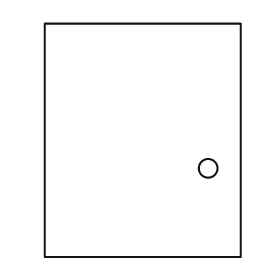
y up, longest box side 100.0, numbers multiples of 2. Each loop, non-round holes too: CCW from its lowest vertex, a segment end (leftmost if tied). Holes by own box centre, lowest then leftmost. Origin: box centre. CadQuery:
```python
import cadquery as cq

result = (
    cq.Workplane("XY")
    .moveTo(-42.0, -50.0)
    .lineTo(42.0, -50.0)
    .lineTo(42.0, 50.0)
    .lineTo(-42.0, 50.0)
    .close()
    .moveTo(28.0, -12.0)
    .circle(4.0)
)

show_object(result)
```